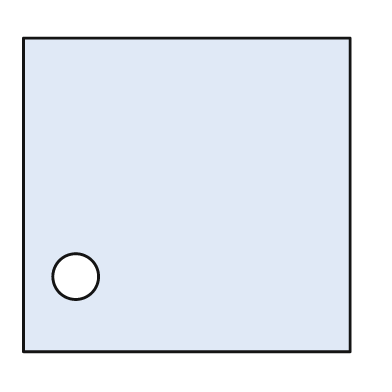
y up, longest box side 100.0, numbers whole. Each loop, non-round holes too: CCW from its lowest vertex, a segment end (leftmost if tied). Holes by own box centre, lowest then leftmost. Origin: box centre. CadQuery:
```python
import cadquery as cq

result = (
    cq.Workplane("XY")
    .moveTo(-50.0, -48.0)
    .lineTo(50.0, -48.0)
    .lineTo(50.0, 48.0)
    .lineTo(-50.0, 48.0)
    .close()
    .moveTo(-34.0, -25.0)
    .circle(7.0)
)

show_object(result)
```